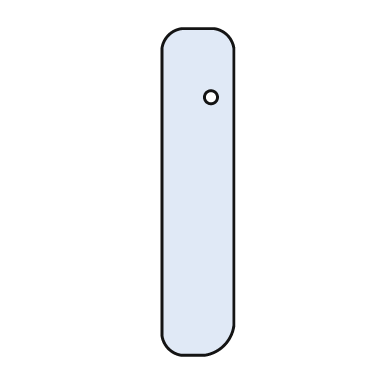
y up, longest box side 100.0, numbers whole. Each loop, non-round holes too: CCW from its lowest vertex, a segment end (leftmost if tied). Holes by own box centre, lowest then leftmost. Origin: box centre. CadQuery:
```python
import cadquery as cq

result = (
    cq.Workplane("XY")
    .moveTo(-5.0, -50.0)
    .lineTo(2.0, -50.0)
    .threePointArc((8.0, -47.0), (11.0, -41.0))
    .lineTo(11.0, 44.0)
    .threePointArc((9.0, 48.0), (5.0, 50.0))
    .lineTo(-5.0, 50.0)
    .threePointArc((-9.0, 48.0), (-11.0, 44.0))
    .lineTo(-11.0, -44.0)
    .threePointArc((-9.0, -48.0), (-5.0, -50.0))
    .close()
    .moveTo(4.0, 29.0)
    .circle(2.0)
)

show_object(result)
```